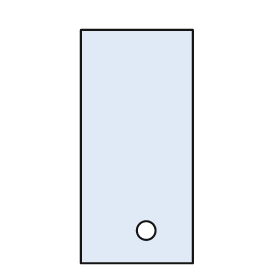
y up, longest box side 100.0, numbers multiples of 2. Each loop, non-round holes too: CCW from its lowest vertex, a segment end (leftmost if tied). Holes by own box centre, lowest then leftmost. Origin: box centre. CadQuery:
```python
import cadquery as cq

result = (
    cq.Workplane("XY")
    .moveTo(-24.0, -50.0)
    .lineTo(24.0, -50.0)
    .lineTo(24.0, 50.0)
    .lineTo(-24.0, 50.0)
    .close()
    .moveTo(4.0, -36.0)
    .circle(4.0)
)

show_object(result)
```